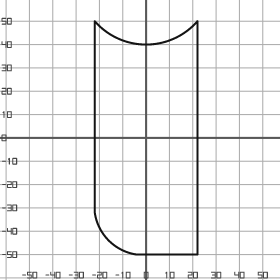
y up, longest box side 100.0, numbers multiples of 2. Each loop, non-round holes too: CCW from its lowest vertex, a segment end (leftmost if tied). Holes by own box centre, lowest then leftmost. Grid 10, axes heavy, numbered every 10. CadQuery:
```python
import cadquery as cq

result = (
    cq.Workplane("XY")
    .moveTo(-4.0, -50.0)
    .lineTo(22.0, -50.0)
    .lineTo(22.0, 50.0)
    .threePointArc((0.0, 40.0), (-22.0, 50.0))
    .lineTo(-22.0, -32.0)
    .threePointArc((-16.0, -44.0), (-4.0, -50.0))
    .close()
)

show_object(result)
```